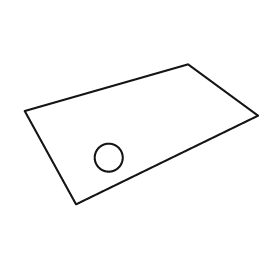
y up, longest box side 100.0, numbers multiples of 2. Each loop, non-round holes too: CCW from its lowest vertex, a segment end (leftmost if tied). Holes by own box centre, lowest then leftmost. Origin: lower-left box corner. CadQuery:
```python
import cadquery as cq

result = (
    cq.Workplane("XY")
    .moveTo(22.0, 0.0)
    .lineTo(100.0, 38.0)
    .lineTo(70.0, 60.0)
    .lineTo(0.0, 40.0)
    .close()
    .moveTo(36.0, 20.0)
    .circle(6.0)
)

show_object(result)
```